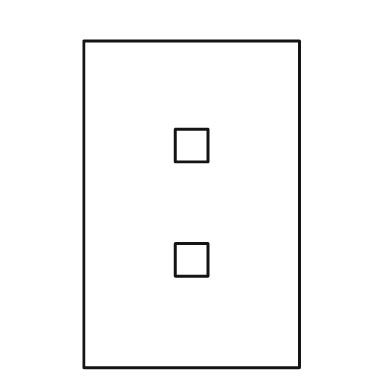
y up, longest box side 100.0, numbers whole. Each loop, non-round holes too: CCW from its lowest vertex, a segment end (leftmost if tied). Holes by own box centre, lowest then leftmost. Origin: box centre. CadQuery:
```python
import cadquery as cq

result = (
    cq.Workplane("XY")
    .moveTo(-33.0, -50.0)
    .lineTo(33.0, -50.0)
    .lineTo(33.0, 50.0)
    .lineTo(-33.0, 50.0)
    .close()
    .moveTo(-5.0, -22.0)
    .lineTo(5.0, -22.0)
    .lineTo(5.0, -12.0)
    .lineTo(-5.0, -12.0)
    .close()
    .moveTo(-5.0, 13.0)
    .lineTo(5.0, 13.0)
    .lineTo(5.0, 23.0)
    .lineTo(-5.0, 23.0)
    .close()
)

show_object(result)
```